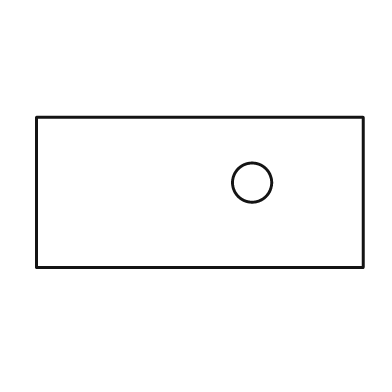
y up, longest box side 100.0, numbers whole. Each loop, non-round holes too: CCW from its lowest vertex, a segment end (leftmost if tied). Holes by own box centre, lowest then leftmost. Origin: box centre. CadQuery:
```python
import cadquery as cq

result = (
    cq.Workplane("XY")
    .moveTo(-50.0, -23.0)
    .lineTo(50.0, -23.0)
    .lineTo(50.0, 23.0)
    .lineTo(-50.0, 23.0)
    .close()
    .moveTo(16.0, 3.0)
    .circle(6.0)
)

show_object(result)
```